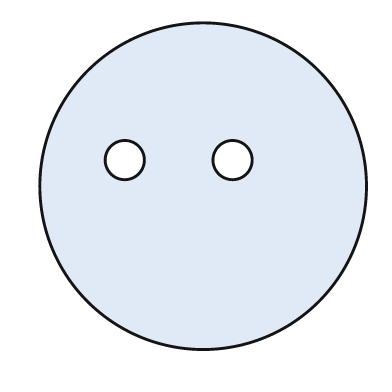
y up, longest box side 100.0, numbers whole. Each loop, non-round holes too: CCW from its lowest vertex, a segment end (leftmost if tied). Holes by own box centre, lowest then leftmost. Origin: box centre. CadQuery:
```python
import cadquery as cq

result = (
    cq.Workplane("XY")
    .moveTo(0.0, 0.0)
    .circle(50.0)
    .moveTo(-24.0, 8.0)
    .circle(6.0)
    .moveTo(9.0, 8.0)
    .circle(6.0)
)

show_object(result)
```